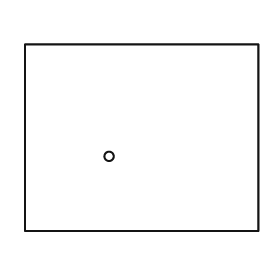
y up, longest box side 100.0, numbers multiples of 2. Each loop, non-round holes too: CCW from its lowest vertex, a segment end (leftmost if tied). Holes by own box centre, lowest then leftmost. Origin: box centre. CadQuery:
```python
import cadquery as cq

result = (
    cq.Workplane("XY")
    .moveTo(-50.0, -40.0)
    .lineTo(50.0, -40.0)
    .lineTo(50.0, 40.0)
    .lineTo(-50.0, 40.0)
    .close()
    .moveTo(-14.0, -8.0)
    .circle(2.0)
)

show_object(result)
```